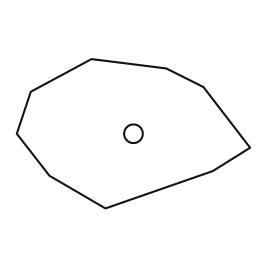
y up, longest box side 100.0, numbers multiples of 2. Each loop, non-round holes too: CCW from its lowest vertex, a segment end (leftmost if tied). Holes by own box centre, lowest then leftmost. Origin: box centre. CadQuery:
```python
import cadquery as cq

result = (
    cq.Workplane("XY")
    .moveTo(-12.0, -32.0)
    .lineTo(34.0, -16.0)
    .lineTo(50.0, -6.0)
    .lineTo(30.0, 20.0)
    .lineTo(14.0, 28.0)
    .lineTo(-18.0, 32.0)
    .lineTo(-44.0, 18.0)
    .lineTo(-50.0, 0.0)
    .lineTo(-36.0, -18.0)
    .close()
    .moveTo(0.0, 0.0)
    .circle(4.0)
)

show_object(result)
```